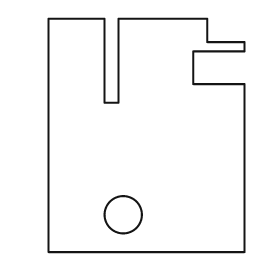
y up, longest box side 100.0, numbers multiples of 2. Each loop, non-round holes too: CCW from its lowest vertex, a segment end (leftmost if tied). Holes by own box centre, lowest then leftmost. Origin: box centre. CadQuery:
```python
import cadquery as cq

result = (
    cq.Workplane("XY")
    .moveTo(-42.0, -50.0)
    .lineTo(42.0, -50.0)
    .lineTo(42.0, 22.0)
    .lineTo(20.0, 22.0)
    .lineTo(20.0, 36.0)
    .lineTo(42.0, 36.0)
    .lineTo(42.0, 40.0)
    .lineTo(26.0, 40.0)
    .lineTo(26.0, 50.0)
    .lineTo(-12.0, 50.0)
    .lineTo(-12.0, 14.0)
    .lineTo(-18.0, 14.0)
    .lineTo(-18.0, 50.0)
    .lineTo(-42.0, 50.0)
    .close()
    .moveTo(-10.0, -34.0)
    .circle(8.0)
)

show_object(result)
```